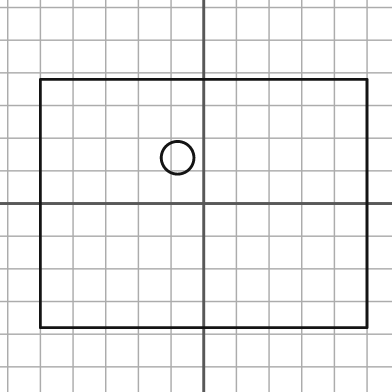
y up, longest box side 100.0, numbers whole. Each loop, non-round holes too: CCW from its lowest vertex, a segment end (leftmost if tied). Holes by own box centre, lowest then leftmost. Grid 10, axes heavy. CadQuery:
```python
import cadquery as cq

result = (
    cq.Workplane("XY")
    .moveTo(-50.0, -38.0)
    .lineTo(50.0, -38.0)
    .lineTo(50.0, 38.0)
    .lineTo(-50.0, 38.0)
    .close()
    .moveTo(-8.0, 14.0)
    .circle(5.0)
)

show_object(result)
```